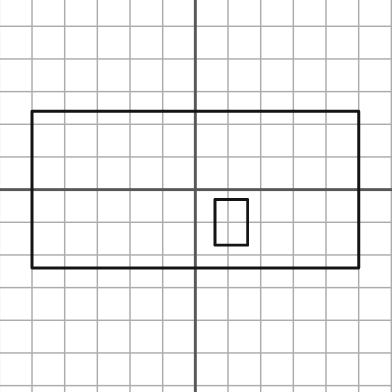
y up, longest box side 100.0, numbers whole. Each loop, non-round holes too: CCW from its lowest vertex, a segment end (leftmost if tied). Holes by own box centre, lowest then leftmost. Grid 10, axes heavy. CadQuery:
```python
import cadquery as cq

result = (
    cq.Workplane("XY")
    .moveTo(-50.0, -24.0)
    .lineTo(50.0, -24.0)
    .lineTo(50.0, 24.0)
    .lineTo(-50.0, 24.0)
    .close()
    .moveTo(6.0, -17.0)
    .lineTo(16.0, -17.0)
    .lineTo(16.0, -3.0)
    .lineTo(6.0, -3.0)
    .close()
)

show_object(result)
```